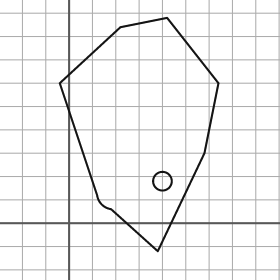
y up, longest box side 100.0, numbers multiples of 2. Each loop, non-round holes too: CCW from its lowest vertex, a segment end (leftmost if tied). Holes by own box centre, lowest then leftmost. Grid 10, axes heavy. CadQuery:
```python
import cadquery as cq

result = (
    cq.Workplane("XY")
    .moveTo(38.0, -12.0)
    .lineTo(58.0, 30.0)
    .lineTo(64.0, 60.0)
    .lineTo(42.0, 88.0)
    .lineTo(22.0, 84.0)
    .lineTo(-4.0, 60.0)
    .lineTo(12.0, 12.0)
    .threePointArc((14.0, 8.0), (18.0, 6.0))
    .close()
    .moveTo(40.0, 18.0)
    .circle(4.0)
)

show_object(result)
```